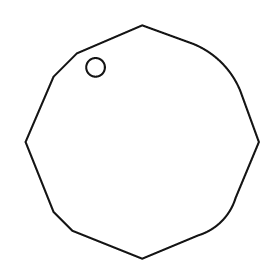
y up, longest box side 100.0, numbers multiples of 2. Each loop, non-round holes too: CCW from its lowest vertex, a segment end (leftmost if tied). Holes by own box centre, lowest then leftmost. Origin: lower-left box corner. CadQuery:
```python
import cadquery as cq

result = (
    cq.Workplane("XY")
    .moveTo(50.0, 0.0)
    .lineTo(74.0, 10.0)
    .threePointArc((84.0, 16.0), (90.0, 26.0))
    .lineTo(100.0, 50.0)
    .lineTo(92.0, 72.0)
    .threePointArc((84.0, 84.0), (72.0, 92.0))
    .lineTo(50.0, 100.0)
    .lineTo(22.0, 88.0)
    .lineTo(12.0, 78.0)
    .lineTo(0.0, 50.0)
    .lineTo(12.0, 20.0)
    .lineTo(20.0, 12.0)
    .close()
    .moveTo(30.0, 82.0)
    .circle(4.0)
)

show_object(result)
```